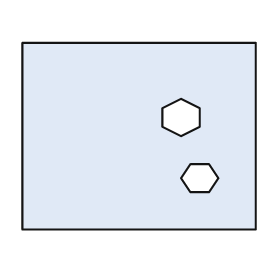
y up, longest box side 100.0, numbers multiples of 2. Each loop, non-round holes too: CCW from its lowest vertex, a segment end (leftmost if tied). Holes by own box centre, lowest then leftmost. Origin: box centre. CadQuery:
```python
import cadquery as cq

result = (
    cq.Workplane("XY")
    .moveTo(-50.0, -40.0)
    .lineTo(50.0, -40.0)
    .lineTo(50.0, 40.0)
    .lineTo(-50.0, 40.0)
    .close()
    .moveTo(22.0, -24.0)
    .lineTo(30.0, -24.0)
    .lineTo(34.0, -18.0)
    .lineTo(30.0, -12.0)
    .lineTo(22.0, -12.0)
    .lineTo(18.0, -18.0)
    .close()
    .moveTo(18.0, 0.0)
    .lineTo(26.0, 4.0)
    .lineTo(26.0, 12.0)
    .lineTo(18.0, 16.0)
    .lineTo(10.0, 12.0)
    .lineTo(10.0, 4.0)
    .close()
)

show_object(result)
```